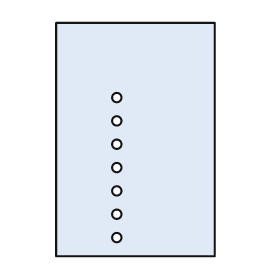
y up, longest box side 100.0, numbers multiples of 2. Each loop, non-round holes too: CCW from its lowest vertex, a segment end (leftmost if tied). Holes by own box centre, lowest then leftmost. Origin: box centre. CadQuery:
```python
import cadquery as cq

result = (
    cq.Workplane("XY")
    .moveTo(-34.0, -50.0)
    .lineTo(34.0, -50.0)
    .lineTo(34.0, 50.0)
    .lineTo(-34.0, 50.0)
    .close()
    .moveTo(-8.0, -42.0)
    .circle(2.0)
    .moveTo(-8.0, -32.0)
    .circle(2.0)
    .moveTo(-8.0, -22.0)
    .circle(2.0)
    .moveTo(-8.0, -12.0)
    .circle(2.0)
    .moveTo(-8.0, -2.0)
    .circle(2.0)
    .moveTo(-8.0, 8.0)
    .circle(2.0)
    .moveTo(-8.0, 18.0)
    .circle(2.0)
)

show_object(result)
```